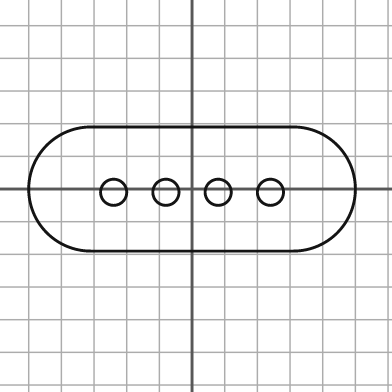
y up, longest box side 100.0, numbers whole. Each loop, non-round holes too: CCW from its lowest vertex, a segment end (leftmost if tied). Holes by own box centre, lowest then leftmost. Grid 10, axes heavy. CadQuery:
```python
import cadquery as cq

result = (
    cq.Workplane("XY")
    .moveTo(-31.0, -19.0)
    .lineTo(31.0, -19.0)
    .threePointArc((50.0, 0.0), (31.0, 19.0))
    .lineTo(-31.0, 19.0)
    .threePointArc((-50.0, 0.0), (-31.0, -19.0))
    .close()
    .moveTo(-24.0, -1.0)
    .circle(4.0)
    .moveTo(-8.0, -1.0)
    .circle(4.0)
    .moveTo(8.0, -1.0)
    .circle(4.0)
    .moveTo(24.0, -1.0)
    .circle(4.0)
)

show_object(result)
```